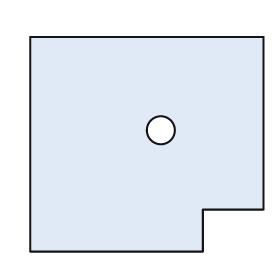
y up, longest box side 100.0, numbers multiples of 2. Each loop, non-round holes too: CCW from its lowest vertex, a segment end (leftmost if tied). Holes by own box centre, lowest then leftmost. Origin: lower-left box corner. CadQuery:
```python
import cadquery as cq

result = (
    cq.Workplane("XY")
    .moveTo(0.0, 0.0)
    .lineTo(74.0, 0.0)
    .lineTo(74.0, 18.0)
    .lineTo(100.0, 18.0)
    .lineTo(100.0, 92.0)
    .lineTo(0.0, 92.0)
    .close()
    .moveTo(56.0, 52.0)
    .circle(6.0)
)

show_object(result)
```